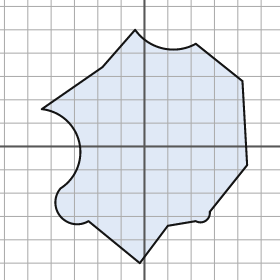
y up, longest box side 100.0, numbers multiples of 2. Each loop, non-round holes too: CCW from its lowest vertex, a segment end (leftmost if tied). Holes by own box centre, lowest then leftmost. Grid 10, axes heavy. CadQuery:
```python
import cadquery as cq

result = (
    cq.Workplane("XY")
    .moveTo(-2.0, -50.0)
    .lineTo(10.0, -34.0)
    .lineTo(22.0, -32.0)
    .threePointArc((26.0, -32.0), (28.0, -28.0))
    .lineTo(44.0, -8.0)
    .lineTo(42.0, 28.0)
    .lineTo(22.0, 44.0)
    .threePointArc((8.0, 42.0), (-4.0, 50.0))
    .lineTo(-18.0, 34.0)
    .lineTo(-44.0, 16.0)
    .threePointArc((-28.0, 2.0), (-36.0, -18.0))
    .threePointArc((-36.0, -30.0), (-24.0, -32.0))
    .close()
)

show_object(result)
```